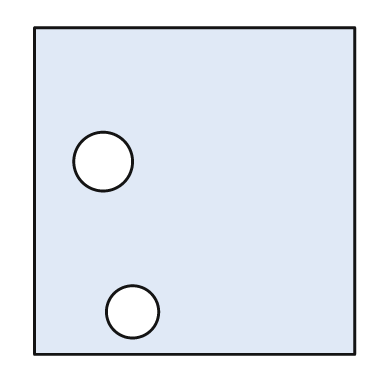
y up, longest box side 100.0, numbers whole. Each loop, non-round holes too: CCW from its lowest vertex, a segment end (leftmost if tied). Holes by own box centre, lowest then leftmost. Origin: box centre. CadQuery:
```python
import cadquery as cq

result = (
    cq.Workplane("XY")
    .moveTo(-49.0, -50.0)
    .lineTo(49.0, -50.0)
    .lineTo(49.0, 50.0)
    .lineTo(-49.0, 50.0)
    .close()
    .moveTo(-19.0, -37.0)
    .circle(8.0)
    .moveTo(-28.0, 9.0)
    .circle(9.0)
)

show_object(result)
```